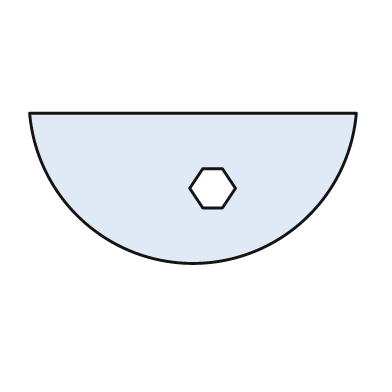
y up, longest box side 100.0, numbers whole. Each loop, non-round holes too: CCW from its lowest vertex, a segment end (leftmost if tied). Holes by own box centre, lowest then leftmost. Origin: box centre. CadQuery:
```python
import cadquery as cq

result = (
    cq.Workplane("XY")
    .moveTo(-50.0, 23.0)
    .threePointArc((0.0, -23.0), (50.0, 23.0))
    .close()
    .moveTo(3.0, -6.0)
    .lineTo(9.0, -6.0)
    .lineTo(13.0, 0.0)
    .lineTo(9.0, 6.0)
    .lineTo(3.0, 6.0)
    .lineTo(-1.0, 0.0)
    .close()
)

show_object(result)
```